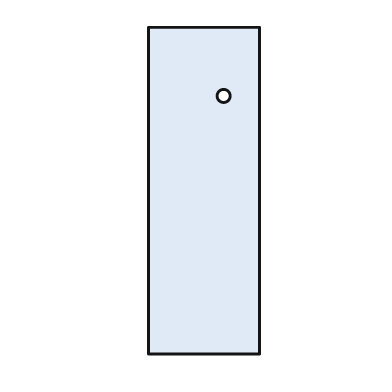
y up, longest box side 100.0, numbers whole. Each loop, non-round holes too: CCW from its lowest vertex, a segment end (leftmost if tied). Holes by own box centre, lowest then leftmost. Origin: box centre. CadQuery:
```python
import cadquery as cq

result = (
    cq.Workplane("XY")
    .moveTo(-17.0, -50.0)
    .lineTo(17.0, -50.0)
    .lineTo(17.0, 50.0)
    .lineTo(-17.0, 50.0)
    .close()
    .moveTo(6.0, 29.0)
    .circle(2.0)
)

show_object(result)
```